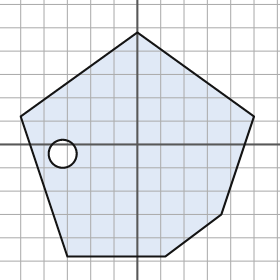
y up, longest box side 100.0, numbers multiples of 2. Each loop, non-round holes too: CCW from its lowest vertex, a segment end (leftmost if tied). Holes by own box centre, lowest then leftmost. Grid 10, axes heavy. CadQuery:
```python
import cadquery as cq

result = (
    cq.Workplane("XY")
    .moveTo(-30.0, -48.0)
    .lineTo(12.0, -48.0)
    .lineTo(36.0, -30.0)
    .lineTo(50.0, 12.0)
    .lineTo(0.0, 48.0)
    .lineTo(-50.0, 12.0)
    .close()
    .moveTo(-32.0, -4.0)
    .circle(6.0)
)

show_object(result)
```